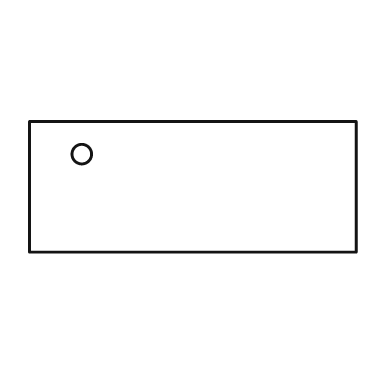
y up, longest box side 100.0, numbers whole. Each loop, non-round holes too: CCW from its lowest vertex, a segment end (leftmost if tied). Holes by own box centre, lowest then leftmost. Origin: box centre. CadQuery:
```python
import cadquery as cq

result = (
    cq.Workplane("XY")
    .moveTo(-50.0, -20.0)
    .lineTo(50.0, -20.0)
    .lineTo(50.0, 20.0)
    .lineTo(-50.0, 20.0)
    .close()
    .moveTo(-34.0, 10.0)
    .circle(3.0)
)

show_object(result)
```